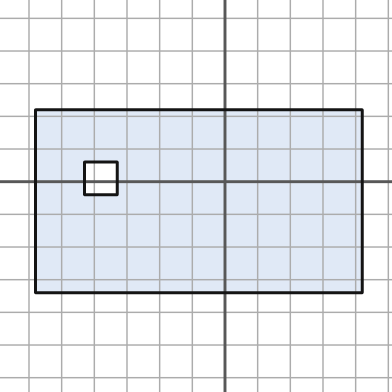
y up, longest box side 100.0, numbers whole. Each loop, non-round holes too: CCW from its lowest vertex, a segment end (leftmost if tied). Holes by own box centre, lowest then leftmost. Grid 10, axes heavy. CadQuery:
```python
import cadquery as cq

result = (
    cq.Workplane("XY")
    .moveTo(-58.0, -34.0)
    .lineTo(42.0, -34.0)
    .lineTo(42.0, 22.0)
    .lineTo(-58.0, 22.0)
    .close()
    .moveTo(-43.0, -4.0)
    .lineTo(-33.0, -4.0)
    .lineTo(-33.0, 6.0)
    .lineTo(-43.0, 6.0)
    .close()
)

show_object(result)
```